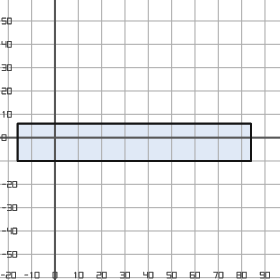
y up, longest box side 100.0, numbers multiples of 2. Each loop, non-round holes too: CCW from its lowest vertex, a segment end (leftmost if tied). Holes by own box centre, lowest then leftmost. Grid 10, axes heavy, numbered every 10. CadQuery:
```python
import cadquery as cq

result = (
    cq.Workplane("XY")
    .moveTo(-16.0, -10.0)
    .lineTo(84.0, -10.0)
    .lineTo(84.0, 6.0)
    .lineTo(-16.0, 6.0)
    .close()
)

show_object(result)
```